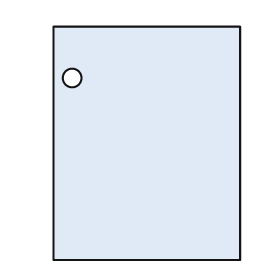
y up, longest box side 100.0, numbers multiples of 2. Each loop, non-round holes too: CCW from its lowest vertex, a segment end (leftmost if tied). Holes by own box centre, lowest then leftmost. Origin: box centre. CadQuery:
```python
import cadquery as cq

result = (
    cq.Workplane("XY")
    .moveTo(-40.0, -50.0)
    .lineTo(40.0, -50.0)
    .lineTo(40.0, 50.0)
    .lineTo(-40.0, 50.0)
    .close()
    .moveTo(-32.0, 28.0)
    .circle(4.0)
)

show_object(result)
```